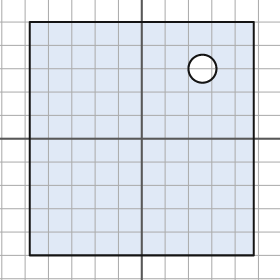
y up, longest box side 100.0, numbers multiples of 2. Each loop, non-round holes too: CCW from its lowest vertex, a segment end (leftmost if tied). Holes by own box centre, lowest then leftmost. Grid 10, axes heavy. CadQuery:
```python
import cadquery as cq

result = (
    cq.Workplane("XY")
    .moveTo(-48.0, -50.0)
    .lineTo(48.0, -50.0)
    .lineTo(48.0, 50.0)
    .lineTo(-48.0, 50.0)
    .close()
    .moveTo(26.0, 30.0)
    .circle(6.0)
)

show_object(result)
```